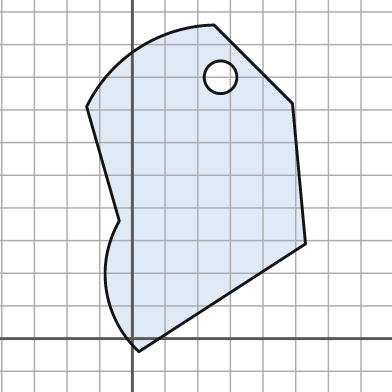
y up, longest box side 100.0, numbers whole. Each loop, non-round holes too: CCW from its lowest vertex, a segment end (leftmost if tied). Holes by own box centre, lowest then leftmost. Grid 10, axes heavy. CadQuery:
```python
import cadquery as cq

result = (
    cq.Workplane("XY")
    .moveTo(2.0, -4.0)
    .lineTo(53.0, 29.0)
    .lineTo(49.0, 72.0)
    .lineTo(25.0, 96.0)
    .threePointArc((2.0, 89.0), (-14.0, 71.0))
    .lineTo(-4.0, 36.0)
    .threePointArc((-8.0, 15.0), (2.0, -4.0))
    .close()
    .moveTo(27.0, 80.0)
    .circle(5.0)
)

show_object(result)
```